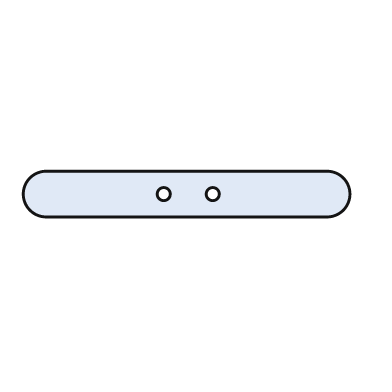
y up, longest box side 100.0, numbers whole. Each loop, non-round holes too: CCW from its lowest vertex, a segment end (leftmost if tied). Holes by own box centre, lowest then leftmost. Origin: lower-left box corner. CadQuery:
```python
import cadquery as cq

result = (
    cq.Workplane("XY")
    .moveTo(7.0, 0.0)
    .lineTo(93.0, 0.0)
    .threePointArc((100.0, 7.0), (93.0, 14.0))
    .lineTo(7.0, 14.0)
    .threePointArc((0.0, 7.0), (7.0, 0.0))
    .close()
    .moveTo(43.0, 7.0)
    .circle(2.0)
    .moveTo(58.0, 7.0)
    .circle(2.0)
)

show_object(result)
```